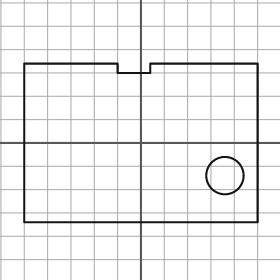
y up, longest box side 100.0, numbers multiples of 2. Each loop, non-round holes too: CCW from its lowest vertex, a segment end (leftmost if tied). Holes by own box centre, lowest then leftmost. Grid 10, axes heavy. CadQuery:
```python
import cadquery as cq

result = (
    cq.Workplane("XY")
    .moveTo(-50.0, -34.0)
    .lineTo(50.0, -34.0)
    .lineTo(50.0, 34.0)
    .lineTo(4.0, 34.0)
    .lineTo(4.0, 30.0)
    .lineTo(-10.0, 30.0)
    .lineTo(-10.0, 34.0)
    .lineTo(-50.0, 34.0)
    .close()
    .moveTo(36.0, -14.0)
    .circle(8.0)
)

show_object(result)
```